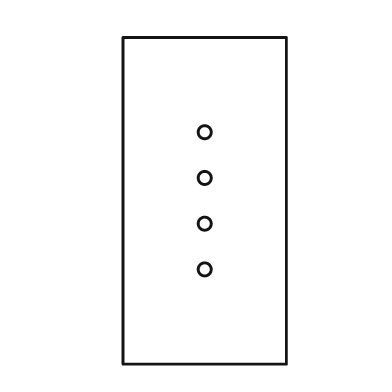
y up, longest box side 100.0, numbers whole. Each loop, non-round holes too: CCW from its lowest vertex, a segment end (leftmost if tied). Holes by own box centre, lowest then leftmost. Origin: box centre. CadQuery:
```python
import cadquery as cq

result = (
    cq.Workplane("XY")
    .moveTo(-25.0, -50.0)
    .lineTo(25.0, -50.0)
    .lineTo(25.0, 50.0)
    .lineTo(-25.0, 50.0)
    .close()
    .moveTo(0.0, -21.0)
    .circle(2.0)
    .moveTo(0.0, -7.0)
    .circle(2.0)
    .moveTo(0.0, 7.0)
    .circle(2.0)
    .moveTo(0.0, 21.0)
    .circle(2.0)
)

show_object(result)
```